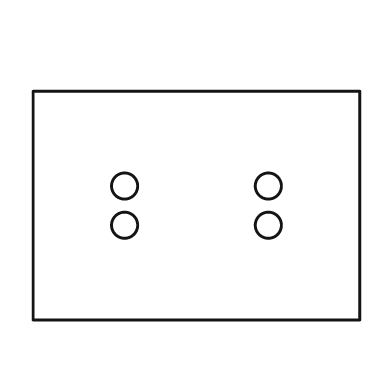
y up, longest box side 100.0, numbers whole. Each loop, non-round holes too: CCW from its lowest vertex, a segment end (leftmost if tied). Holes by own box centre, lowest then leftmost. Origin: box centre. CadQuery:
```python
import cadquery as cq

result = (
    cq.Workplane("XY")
    .moveTo(-50.0, -35.0)
    .lineTo(50.0, -35.0)
    .lineTo(50.0, 35.0)
    .lineTo(-50.0, 35.0)
    .close()
    .moveTo(-22.0, -6.0)
    .circle(4.0)
    .moveTo(22.0, -6.0)
    .circle(4.0)
    .moveTo(-22.0, 6.0)
    .circle(4.0)
    .moveTo(22.0, 6.0)
    .circle(4.0)
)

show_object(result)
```